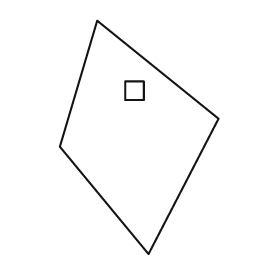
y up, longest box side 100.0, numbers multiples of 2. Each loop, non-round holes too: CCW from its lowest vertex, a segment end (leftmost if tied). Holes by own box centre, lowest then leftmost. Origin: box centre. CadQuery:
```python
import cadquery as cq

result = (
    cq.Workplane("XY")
    .moveTo(4.0, -50.0)
    .lineTo(34.0, 8.0)
    .lineTo(-18.0, 50.0)
    .lineTo(-34.0, -4.0)
    .close()
    .moveTo(-6.0, 16.0)
    .lineTo(2.0, 16.0)
    .lineTo(2.0, 24.0)
    .lineTo(-6.0, 24.0)
    .close()
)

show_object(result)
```